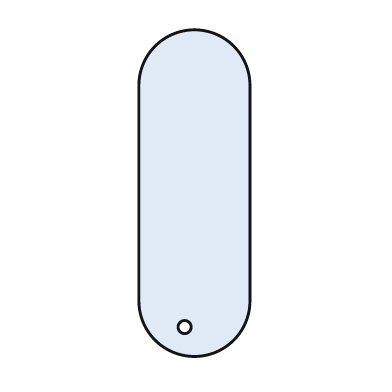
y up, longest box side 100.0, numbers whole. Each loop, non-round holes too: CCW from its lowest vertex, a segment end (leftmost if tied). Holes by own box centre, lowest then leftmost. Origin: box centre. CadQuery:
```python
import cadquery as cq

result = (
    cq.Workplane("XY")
    .moveTo(-17.0, -33.0)
    .threePointArc((0.0, -50.0), (17.0, -33.0))
    .lineTo(17.0, 33.0)
    .threePointArc((0.0, 50.0), (-17.0, 33.0))
    .close()
    .moveTo(-3.0, -41.0)
    .circle(2.0)
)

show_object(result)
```